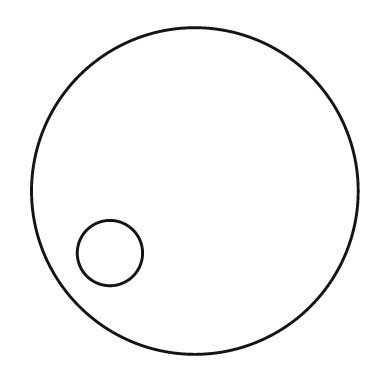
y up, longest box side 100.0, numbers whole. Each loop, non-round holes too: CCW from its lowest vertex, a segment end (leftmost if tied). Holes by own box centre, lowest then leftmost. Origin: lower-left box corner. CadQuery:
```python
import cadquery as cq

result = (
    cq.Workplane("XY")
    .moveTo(50.0, 50.0)
    .circle(50.0)
    .moveTo(24.0, 31.0)
    .circle(10.0)
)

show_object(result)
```